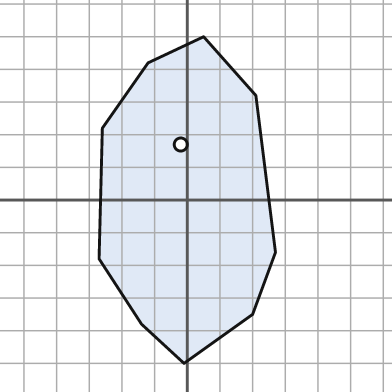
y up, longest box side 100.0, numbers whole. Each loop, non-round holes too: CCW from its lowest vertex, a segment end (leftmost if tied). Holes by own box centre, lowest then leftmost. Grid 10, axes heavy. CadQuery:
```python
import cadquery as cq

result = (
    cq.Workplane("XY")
    .moveTo(-1.0, -50.0)
    .lineTo(20.0, -35.0)
    .lineTo(27.0, -16.0)
    .lineTo(21.0, 32.0)
    .lineTo(5.0, 50.0)
    .lineTo(-12.0, 42.0)
    .lineTo(-26.0, 22.0)
    .lineTo(-27.0, -18.0)
    .lineTo(-14.0, -38.0)
    .close()
    .moveTo(-2.0, 17.0)
    .circle(2.0)
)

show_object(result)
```